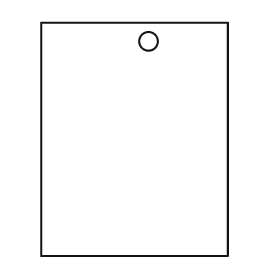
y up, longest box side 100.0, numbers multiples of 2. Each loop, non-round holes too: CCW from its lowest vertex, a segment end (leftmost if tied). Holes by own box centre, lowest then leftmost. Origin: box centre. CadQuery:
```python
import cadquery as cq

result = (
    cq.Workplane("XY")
    .moveTo(-40.0, -50.0)
    .lineTo(40.0, -50.0)
    .lineTo(40.0, 50.0)
    .lineTo(-40.0, 50.0)
    .close()
    .moveTo(6.0, 42.0)
    .circle(4.0)
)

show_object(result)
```